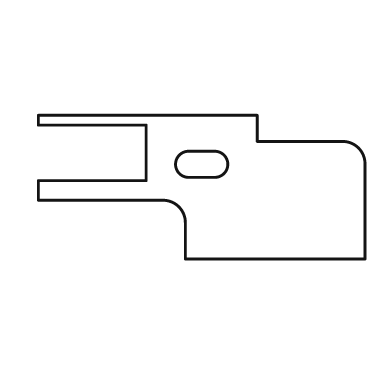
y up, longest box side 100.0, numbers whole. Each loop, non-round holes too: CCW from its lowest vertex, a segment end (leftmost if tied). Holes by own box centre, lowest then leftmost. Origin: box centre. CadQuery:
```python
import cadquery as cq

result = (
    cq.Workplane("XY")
    .moveTo(-5.0, -22.0)
    .lineTo(50.0, -22.0)
    .lineTo(50.0, 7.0)
    .threePointArc((48.0, 12.0), (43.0, 14.0))
    .lineTo(17.0, 14.0)
    .lineTo(17.0, 22.0)
    .lineTo(-50.0, 22.0)
    .lineTo(-50.0, 19.0)
    .lineTo(-17.0, 19.0)
    .lineTo(-17.0, 2.0)
    .lineTo(-50.0, 2.0)
    .lineTo(-50.0, -4.0)
    .lineTo(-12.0, -4.0)
    .threePointArc((-7.0, -6.0), (-5.0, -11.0))
    .close()
    .moveTo(-4.0, 3.0)
    .lineTo(4.0, 3.0)
    .threePointArc((8.0, 7.0), (4.0, 11.0))
    .lineTo(-4.0, 11.0)
    .threePointArc((-8.0, 7.0), (-4.0, 3.0))
    .close()
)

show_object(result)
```